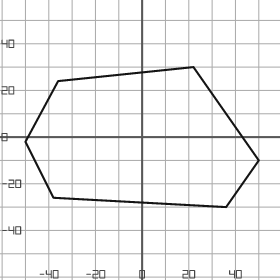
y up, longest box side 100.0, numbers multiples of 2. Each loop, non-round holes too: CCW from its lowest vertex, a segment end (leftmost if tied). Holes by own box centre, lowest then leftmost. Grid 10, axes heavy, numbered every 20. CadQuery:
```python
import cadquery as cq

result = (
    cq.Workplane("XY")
    .moveTo(36.0, -30.0)
    .lineTo(50.0, -10.0)
    .lineTo(22.0, 30.0)
    .lineTo(-36.0, 24.0)
    .lineTo(-50.0, -2.0)
    .lineTo(-38.0, -26.0)
    .close()
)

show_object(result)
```